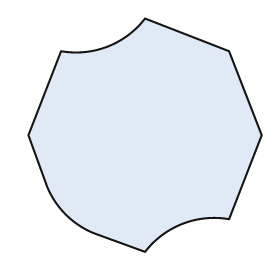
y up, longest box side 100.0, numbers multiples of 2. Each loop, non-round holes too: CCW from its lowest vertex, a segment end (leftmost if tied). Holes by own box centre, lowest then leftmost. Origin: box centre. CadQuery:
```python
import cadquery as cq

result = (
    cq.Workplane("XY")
    .moveTo(0.0, -50.0)
    .threePointArc((16.0, -38.0), (36.0, -36.0))
    .lineTo(50.0, 0.0)
    .lineTo(36.0, 36.0)
    .lineTo(0.0, 50.0)
    .threePointArc((-16.0, 38.0), (-36.0, 36.0))
    .lineTo(-50.0, 0.0)
    .lineTo(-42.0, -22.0)
    .threePointArc((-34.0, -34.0), (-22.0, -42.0))
    .close()
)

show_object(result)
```